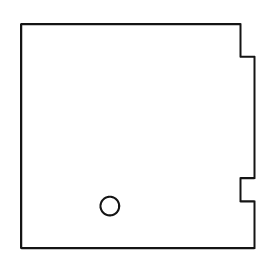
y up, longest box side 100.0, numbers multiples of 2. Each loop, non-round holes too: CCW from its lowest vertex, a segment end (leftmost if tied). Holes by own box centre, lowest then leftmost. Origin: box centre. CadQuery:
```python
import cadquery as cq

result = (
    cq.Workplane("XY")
    .moveTo(-50.0, -48.0)
    .lineTo(50.0, -48.0)
    .lineTo(50.0, -28.0)
    .lineTo(44.0, -28.0)
    .lineTo(44.0, -18.0)
    .lineTo(50.0, -18.0)
    .lineTo(50.0, 34.0)
    .lineTo(44.0, 34.0)
    .lineTo(44.0, 48.0)
    .lineTo(-50.0, 48.0)
    .close()
    .moveTo(-12.0, -30.0)
    .circle(4.0)
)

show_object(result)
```